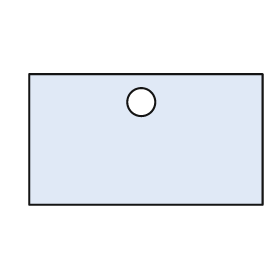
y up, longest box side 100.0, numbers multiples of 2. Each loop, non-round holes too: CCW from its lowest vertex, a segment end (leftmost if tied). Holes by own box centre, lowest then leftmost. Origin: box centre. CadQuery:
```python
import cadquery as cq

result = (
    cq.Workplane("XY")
    .moveTo(-50.0, -28.0)
    .lineTo(50.0, -28.0)
    .lineTo(50.0, 28.0)
    .lineTo(-50.0, 28.0)
    .close()
    .moveTo(-2.0, 16.0)
    .circle(6.0)
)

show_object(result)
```